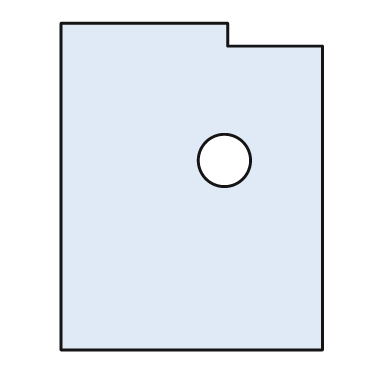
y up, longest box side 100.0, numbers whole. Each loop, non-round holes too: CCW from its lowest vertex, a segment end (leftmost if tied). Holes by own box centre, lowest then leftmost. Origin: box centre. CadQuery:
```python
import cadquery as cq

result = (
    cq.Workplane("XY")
    .moveTo(-40.0, -50.0)
    .lineTo(40.0, -50.0)
    .lineTo(40.0, 43.0)
    .lineTo(11.0, 43.0)
    .lineTo(11.0, 50.0)
    .lineTo(-40.0, 50.0)
    .close()
    .moveTo(10.0, 8.0)
    .circle(8.0)
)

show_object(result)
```